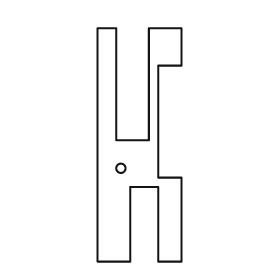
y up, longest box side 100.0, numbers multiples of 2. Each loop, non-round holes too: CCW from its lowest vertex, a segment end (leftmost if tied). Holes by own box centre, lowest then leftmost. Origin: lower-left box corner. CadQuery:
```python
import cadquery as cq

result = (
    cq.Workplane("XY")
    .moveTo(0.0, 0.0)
    .lineTo(14.0, 0.0)
    .lineTo(14.0, 32.0)
    .lineTo(26.0, 32.0)
    .lineTo(26.0, 0.0)
    .lineTo(36.0, 0.0)
    .lineTo(36.0, 36.0)
    .lineTo(26.0, 36.0)
    .lineTo(26.0, 84.0)
    .lineTo(36.0, 84.0)
    .lineTo(36.0, 100.0)
    .lineTo(22.0, 100.0)
    .lineTo(22.0, 52.0)
    .lineTo(8.0, 52.0)
    .lineTo(8.0, 100.0)
    .lineTo(0.0, 100.0)
    .close()
    .moveTo(10.0, 40.0)
    .circle(2.0)
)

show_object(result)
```